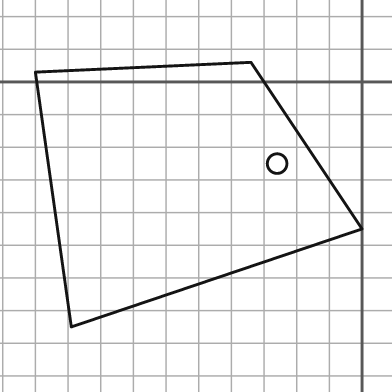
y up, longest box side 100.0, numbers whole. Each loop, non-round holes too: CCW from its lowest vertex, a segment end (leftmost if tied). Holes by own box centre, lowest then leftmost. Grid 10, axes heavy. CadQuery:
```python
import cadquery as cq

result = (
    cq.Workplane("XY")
    .moveTo(-89.0, -75.0)
    .lineTo(0.0, -45.0)
    .lineTo(-34.0, 6.0)
    .lineTo(-100.0, 3.0)
    .close()
    .moveTo(-26.0, -25.0)
    .circle(3.0)
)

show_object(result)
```